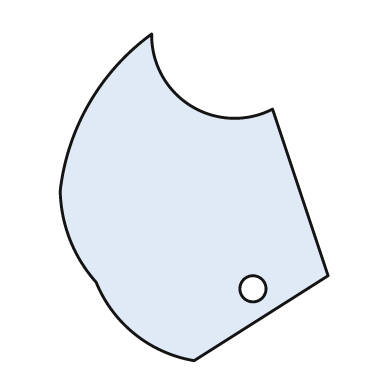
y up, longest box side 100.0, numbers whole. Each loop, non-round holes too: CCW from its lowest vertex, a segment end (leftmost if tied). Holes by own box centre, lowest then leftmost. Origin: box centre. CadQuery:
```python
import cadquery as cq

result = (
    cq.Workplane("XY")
    .moveTo(0.0, -50.0)
    .lineTo(41.0, -24.0)
    .lineTo(24.0, 27.0)
    .threePointArc((-1.0, 28.0), (-13.0, 50.0))
    .threePointArc((-32.0, 29.0), (-41.0, 2.0))
    .threePointArc((-38.0, -13.0), (-30.0, -26.0))
    .threePointArc((-18.0, -42.0), (0.0, -50.0))
    .close()
    .moveTo(18.0, -28.0)
    .circle(4.0)
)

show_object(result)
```